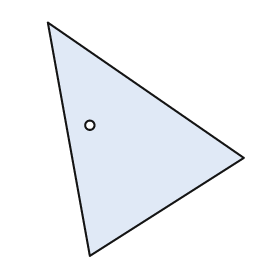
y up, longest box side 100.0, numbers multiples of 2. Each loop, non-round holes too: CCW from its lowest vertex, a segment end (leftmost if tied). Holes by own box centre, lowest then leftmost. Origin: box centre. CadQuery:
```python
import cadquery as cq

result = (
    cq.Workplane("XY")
    .moveTo(-24.0, -50.0)
    .lineTo(42.0, -8.0)
    .lineTo(-42.0, 50.0)
    .close()
    .moveTo(-24.0, 6.0)
    .circle(2.0)
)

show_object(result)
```